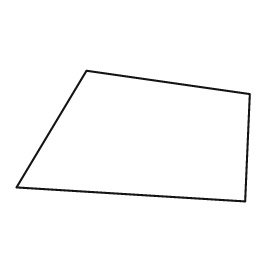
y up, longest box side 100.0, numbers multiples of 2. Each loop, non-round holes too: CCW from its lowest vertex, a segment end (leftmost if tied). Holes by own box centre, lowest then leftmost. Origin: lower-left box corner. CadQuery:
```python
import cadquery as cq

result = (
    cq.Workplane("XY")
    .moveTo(98.0, 0.0)
    .lineTo(100.0, 46.0)
    .lineTo(30.0, 56.0)
    .lineTo(0.0, 6.0)
    .close()
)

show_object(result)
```